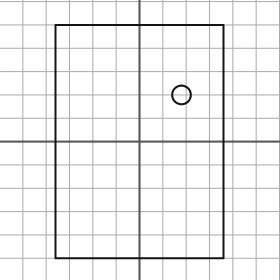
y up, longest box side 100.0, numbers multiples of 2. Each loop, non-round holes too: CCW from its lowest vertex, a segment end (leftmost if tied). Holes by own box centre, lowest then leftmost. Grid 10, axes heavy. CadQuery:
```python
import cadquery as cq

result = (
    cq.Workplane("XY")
    .moveTo(-36.0, -50.0)
    .lineTo(36.0, -50.0)
    .lineTo(36.0, 50.0)
    .lineTo(-36.0, 50.0)
    .close()
    .moveTo(18.0, 20.0)
    .circle(4.0)
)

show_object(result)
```